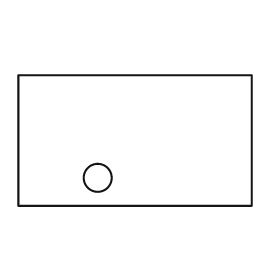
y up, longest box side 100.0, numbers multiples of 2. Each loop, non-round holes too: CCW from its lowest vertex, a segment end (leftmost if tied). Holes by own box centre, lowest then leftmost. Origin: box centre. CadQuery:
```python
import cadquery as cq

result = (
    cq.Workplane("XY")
    .moveTo(-50.0, -28.0)
    .lineTo(50.0, -28.0)
    .lineTo(50.0, 28.0)
    .lineTo(-50.0, 28.0)
    .close()
    .moveTo(-16.0, -16.0)
    .circle(6.0)
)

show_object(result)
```